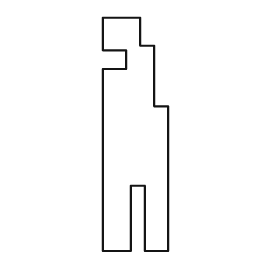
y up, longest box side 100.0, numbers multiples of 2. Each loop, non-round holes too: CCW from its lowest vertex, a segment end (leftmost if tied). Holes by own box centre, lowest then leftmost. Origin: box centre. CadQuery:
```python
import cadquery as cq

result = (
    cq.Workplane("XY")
    .moveTo(-14.0, -50.0)
    .lineTo(-2.0, -50.0)
    .lineTo(-2.0, -22.0)
    .lineTo(4.0, -22.0)
    .lineTo(4.0, -50.0)
    .lineTo(14.0, -50.0)
    .lineTo(14.0, 12.0)
    .lineTo(8.0, 12.0)
    .lineTo(8.0, 38.0)
    .lineTo(2.0, 38.0)
    .lineTo(2.0, 50.0)
    .lineTo(-14.0, 50.0)
    .lineTo(-14.0, 36.0)
    .lineTo(-4.0, 36.0)
    .lineTo(-4.0, 28.0)
    .lineTo(-14.0, 28.0)
    .close()
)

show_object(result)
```